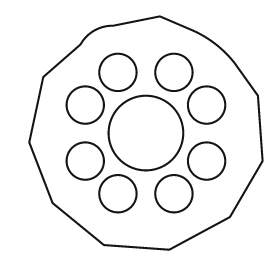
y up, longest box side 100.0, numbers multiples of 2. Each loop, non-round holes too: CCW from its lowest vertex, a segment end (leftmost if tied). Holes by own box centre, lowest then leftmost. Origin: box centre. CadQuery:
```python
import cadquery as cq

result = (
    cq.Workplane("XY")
    .moveTo(10.0, -50.0)
    .lineTo(36.0, -36.0)
    .lineTo(50.0, -12.0)
    .lineTo(48.0, 16.0)
    .lineTo(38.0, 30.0)
    .threePointArc((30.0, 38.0), (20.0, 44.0))
    .lineTo(6.0, 50.0)
    .lineTo(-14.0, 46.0)
    .threePointArc((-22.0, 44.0), (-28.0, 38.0))
    .lineTo(-44.0, 24.0)
    .lineTo(-50.0, -4.0)
    .lineTo(-40.0, -30.0)
    .lineTo(-18.0, -48.0)
    .close()
    .moveTo(-12.0, -26.0)
    .circle(8.0)
    .moveTo(12.0, -26.0)
    .circle(8.0)
    .moveTo(-26.0, -12.0)
    .circle(8.0)
    .moveTo(26.0, -12.0)
    .circle(8.0)
    .moveTo(0.0, 0.0)
    .circle(16.0)
    .moveTo(-26.0, 12.0)
    .circle(8.0)
    .moveTo(26.0, 12.0)
    .circle(8.0)
    .moveTo(-12.0, 26.0)
    .circle(8.0)
    .moveTo(12.0, 26.0)
    .circle(8.0)
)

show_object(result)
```